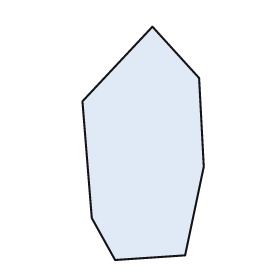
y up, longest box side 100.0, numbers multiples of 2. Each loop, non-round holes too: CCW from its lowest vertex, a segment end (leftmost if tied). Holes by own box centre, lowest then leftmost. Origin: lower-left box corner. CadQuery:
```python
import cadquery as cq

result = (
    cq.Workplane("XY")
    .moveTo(14.0, 0.0)
    .lineTo(44.0, 2.0)
    .lineTo(52.0, 40.0)
    .lineTo(50.0, 78.0)
    .lineTo(30.0, 100.0)
    .lineTo(0.0, 68.0)
    .lineTo(4.0, 18.0)
    .close()
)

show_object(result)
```